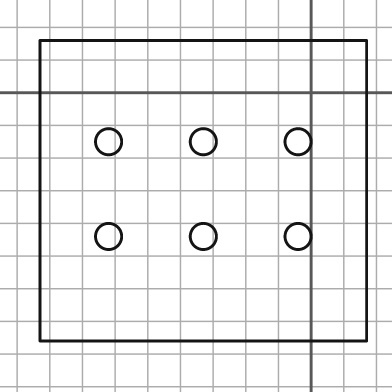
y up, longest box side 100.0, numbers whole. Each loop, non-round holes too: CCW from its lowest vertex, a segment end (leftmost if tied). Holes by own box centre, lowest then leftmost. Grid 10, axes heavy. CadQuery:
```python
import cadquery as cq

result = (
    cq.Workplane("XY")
    .moveTo(-83.0, -76.0)
    .lineTo(17.0, -76.0)
    .lineTo(17.0, 16.0)
    .lineTo(-83.0, 16.0)
    .close()
    .moveTo(-62.0, -44.0)
    .circle(4.0)
    .moveTo(-33.0, -44.0)
    .circle(4.0)
    .moveTo(-4.0, -44.0)
    .circle(4.0)
    .moveTo(-62.0, -15.0)
    .circle(4.0)
    .moveTo(-33.0, -15.0)
    .circle(4.0)
    .moveTo(-4.0, -15.0)
    .circle(4.0)
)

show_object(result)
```